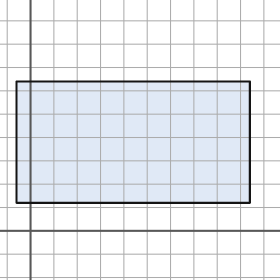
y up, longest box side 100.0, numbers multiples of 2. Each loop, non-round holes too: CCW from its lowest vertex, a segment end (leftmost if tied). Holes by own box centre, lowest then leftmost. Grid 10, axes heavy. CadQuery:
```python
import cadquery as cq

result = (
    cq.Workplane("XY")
    .moveTo(-6.0, 12.0)
    .lineTo(94.0, 12.0)
    .lineTo(94.0, 64.0)
    .lineTo(-6.0, 64.0)
    .close()
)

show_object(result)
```